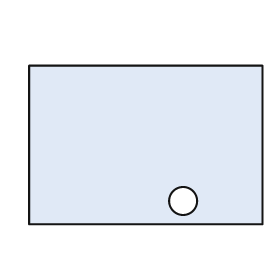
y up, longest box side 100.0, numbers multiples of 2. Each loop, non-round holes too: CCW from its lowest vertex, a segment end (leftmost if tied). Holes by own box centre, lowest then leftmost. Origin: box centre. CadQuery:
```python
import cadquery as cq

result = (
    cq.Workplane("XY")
    .moveTo(-50.0, -34.0)
    .lineTo(50.0, -34.0)
    .lineTo(50.0, 34.0)
    .lineTo(-50.0, 34.0)
    .close()
    .moveTo(16.0, -24.0)
    .circle(6.0)
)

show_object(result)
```